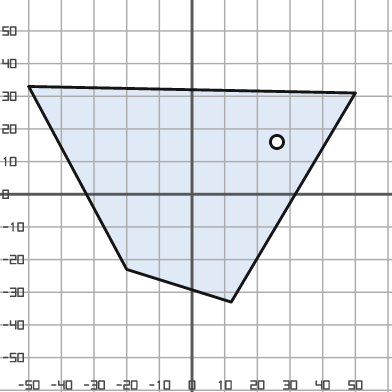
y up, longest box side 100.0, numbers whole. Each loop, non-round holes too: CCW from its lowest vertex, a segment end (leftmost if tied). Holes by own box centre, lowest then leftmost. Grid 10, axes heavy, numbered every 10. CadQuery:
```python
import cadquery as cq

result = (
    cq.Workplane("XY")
    .moveTo(12.0, -33.0)
    .lineTo(50.0, 31.0)
    .lineTo(-50.0, 33.0)
    .lineTo(-20.0, -23.0)
    .close()
    .moveTo(26.0, 16.0)
    .circle(2.0)
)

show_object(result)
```